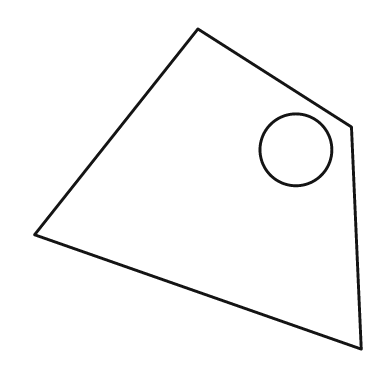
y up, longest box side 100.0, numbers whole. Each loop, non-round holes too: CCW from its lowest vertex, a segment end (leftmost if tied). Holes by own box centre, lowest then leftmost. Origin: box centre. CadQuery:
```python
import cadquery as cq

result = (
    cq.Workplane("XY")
    .moveTo(50.0, -49.0)
    .lineTo(47.0, 19.0)
    .lineTo(0.0, 49.0)
    .lineTo(-50.0, -14.0)
    .close()
    .moveTo(30.0, 12.0)
    .circle(11.0)
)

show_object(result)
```